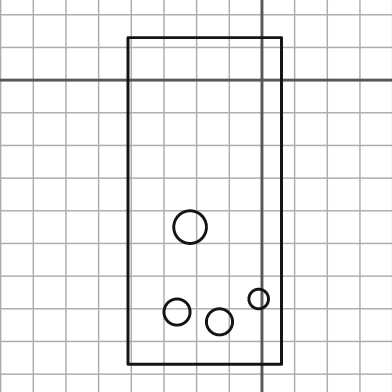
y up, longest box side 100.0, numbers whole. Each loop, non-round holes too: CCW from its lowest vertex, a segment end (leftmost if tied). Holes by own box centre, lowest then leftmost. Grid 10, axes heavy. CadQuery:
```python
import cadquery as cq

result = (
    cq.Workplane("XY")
    .moveTo(-41.0, -87.0)
    .lineTo(6.0, -87.0)
    .lineTo(6.0, 13.0)
    .lineTo(-41.0, 13.0)
    .close()
    .moveTo(-13.0, -74.0)
    .circle(4.0)
    .moveTo(-26.0, -71.0)
    .circle(4.0)
    .moveTo(-1.0, -67.0)
    .circle(3.0)
    .moveTo(-22.0, -45.0)
    .circle(5.0)
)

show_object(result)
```